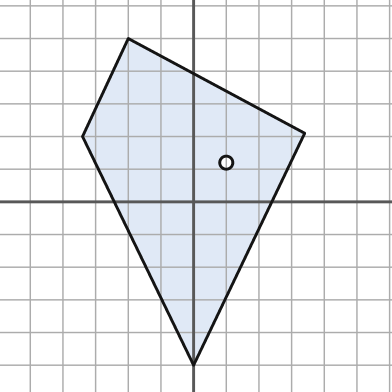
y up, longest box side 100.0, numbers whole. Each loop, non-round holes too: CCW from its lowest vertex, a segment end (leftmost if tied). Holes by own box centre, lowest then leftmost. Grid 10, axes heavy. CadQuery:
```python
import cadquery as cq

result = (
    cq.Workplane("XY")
    .moveTo(0.0, -50.0)
    .lineTo(34.0, 21.0)
    .lineTo(-20.0, 50.0)
    .lineTo(-34.0, 20.0)
    .close()
    .moveTo(10.0, 12.0)
    .circle(2.0)
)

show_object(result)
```